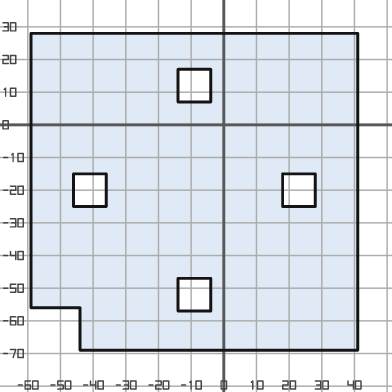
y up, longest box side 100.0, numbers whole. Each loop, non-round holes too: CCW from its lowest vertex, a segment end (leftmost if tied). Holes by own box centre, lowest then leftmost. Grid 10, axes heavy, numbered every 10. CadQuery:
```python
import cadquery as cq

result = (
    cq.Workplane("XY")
    .moveTo(-44.0, -69.0)
    .lineTo(41.0, -69.0)
    .lineTo(41.0, 28.0)
    .lineTo(-59.0, 28.0)
    .lineTo(-59.0, -56.0)
    .lineTo(-44.0, -56.0)
    .close()
    .moveTo(-14.0, -57.0)
    .lineTo(-4.0, -57.0)
    .lineTo(-4.0, -47.0)
    .lineTo(-14.0, -47.0)
    .close()
    .moveTo(-46.0, -25.0)
    .lineTo(-36.0, -25.0)
    .lineTo(-36.0, -15.0)
    .lineTo(-46.0, -15.0)
    .close()
    .moveTo(18.0, -25.0)
    .lineTo(28.0, -25.0)
    .lineTo(28.0, -15.0)
    .lineTo(18.0, -15.0)
    .close()
    .moveTo(-14.0, 7.0)
    .lineTo(-4.0, 7.0)
    .lineTo(-4.0, 17.0)
    .lineTo(-14.0, 17.0)
    .close()
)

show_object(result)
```